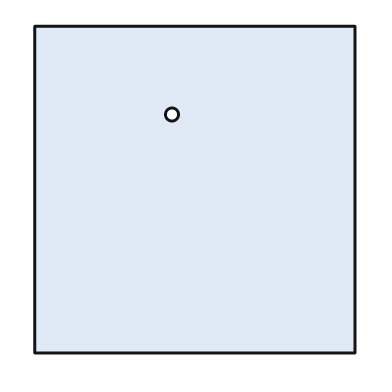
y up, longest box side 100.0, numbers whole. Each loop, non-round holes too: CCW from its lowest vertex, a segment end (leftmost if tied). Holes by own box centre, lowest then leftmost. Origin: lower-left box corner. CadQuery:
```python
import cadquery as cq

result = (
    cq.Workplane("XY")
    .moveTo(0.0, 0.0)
    .lineTo(98.0, 0.0)
    .lineTo(98.0, 100.0)
    .lineTo(0.0, 100.0)
    .close()
    .moveTo(42.0, 73.0)
    .circle(2.0)
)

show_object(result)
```